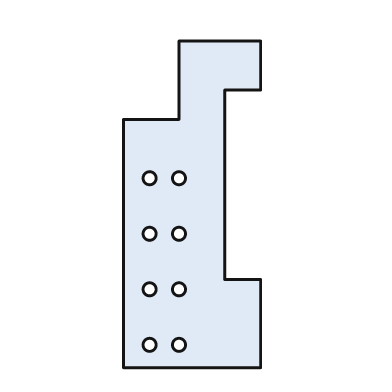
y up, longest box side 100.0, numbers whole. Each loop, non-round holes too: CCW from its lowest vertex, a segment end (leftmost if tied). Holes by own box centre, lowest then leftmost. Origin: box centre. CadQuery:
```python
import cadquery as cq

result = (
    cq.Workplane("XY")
    .moveTo(-21.0, -50.0)
    .lineTo(21.0, -50.0)
    .lineTo(21.0, -23.0)
    .lineTo(10.0, -23.0)
    .lineTo(10.0, 35.0)
    .lineTo(21.0, 35.0)
    .lineTo(21.0, 50.0)
    .lineTo(-4.0, 50.0)
    .lineTo(-4.0, 26.0)
    .lineTo(-21.0, 26.0)
    .close()
    .moveTo(-13.0, -43.0)
    .circle(2.0)
    .moveTo(-4.0, -43.0)
    .circle(2.0)
    .moveTo(-13.0, -26.0)
    .circle(2.0)
    .moveTo(-4.0, -26.0)
    .circle(2.0)
    .moveTo(-13.0, -9.0)
    .circle(2.0)
    .moveTo(-4.0, -9.0)
    .circle(2.0)
    .moveTo(-13.0, 8.0)
    .circle(2.0)
    .moveTo(-4.0, 8.0)
    .circle(2.0)
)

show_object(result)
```